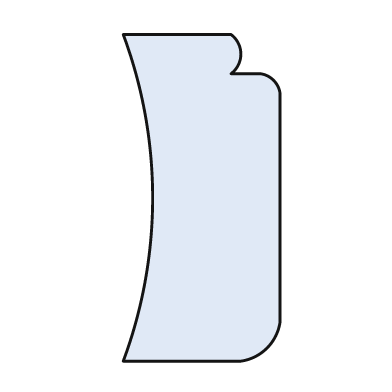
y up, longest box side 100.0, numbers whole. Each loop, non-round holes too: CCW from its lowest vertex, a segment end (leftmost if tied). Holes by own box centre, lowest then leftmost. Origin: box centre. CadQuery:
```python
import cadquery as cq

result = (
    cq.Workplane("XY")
    .moveTo(-24.0, -50.0)
    .lineTo(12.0, -50.0)
    .threePointArc((20.0, -46.0), (24.0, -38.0))
    .lineTo(24.0, 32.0)
    .threePointArc((22.0, 36.0), (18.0, 38.0))
    .lineTo(9.0, 38.0)
    .threePointArc((12.0, 44.0), (9.0, 50.0))
    .lineTo(-24.0, 50.0)
    .threePointArc((-15.0, 0.0), (-24.0, -50.0))
    .close()
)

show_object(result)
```